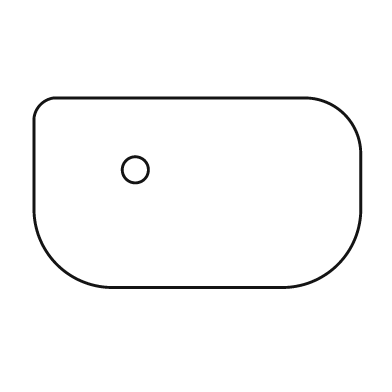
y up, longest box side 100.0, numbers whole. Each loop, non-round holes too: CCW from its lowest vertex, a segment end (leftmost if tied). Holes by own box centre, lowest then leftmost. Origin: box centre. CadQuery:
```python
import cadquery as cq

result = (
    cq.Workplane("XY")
    .moveTo(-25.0, -29.0)
    .lineTo(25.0, -29.0)
    .threePointArc((43.0, -22.0), (50.0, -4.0))
    .lineTo(50.0, 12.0)
    .threePointArc((45.0, 24.0), (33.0, 29.0))
    .lineTo(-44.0, 29.0)
    .threePointArc((-48.0, 27.0), (-50.0, 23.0))
    .lineTo(-50.0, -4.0)
    .threePointArc((-43.0, -22.0), (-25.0, -29.0))
    .close()
    .moveTo(-19.0, 7.0)
    .circle(4.0)
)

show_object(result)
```